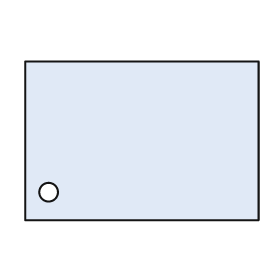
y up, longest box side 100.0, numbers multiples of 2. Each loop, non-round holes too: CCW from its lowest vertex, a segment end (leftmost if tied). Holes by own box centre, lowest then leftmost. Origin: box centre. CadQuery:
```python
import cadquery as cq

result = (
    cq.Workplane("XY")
    .moveTo(-50.0, -34.0)
    .lineTo(50.0, -34.0)
    .lineTo(50.0, 34.0)
    .lineTo(-50.0, 34.0)
    .close()
    .moveTo(-40.0, -22.0)
    .circle(4.0)
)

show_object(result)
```